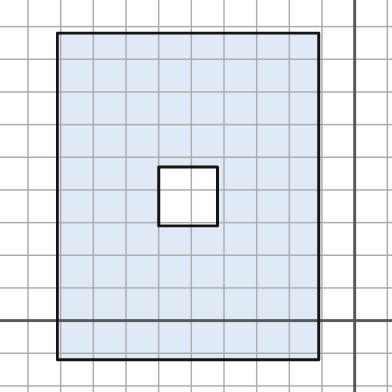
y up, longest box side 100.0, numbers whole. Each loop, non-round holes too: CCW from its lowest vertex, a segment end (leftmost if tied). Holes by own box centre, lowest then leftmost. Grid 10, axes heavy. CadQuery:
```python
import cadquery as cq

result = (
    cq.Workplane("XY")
    .moveTo(-91.0, -12.0)
    .lineTo(-11.0, -12.0)
    .lineTo(-11.0, 88.0)
    .lineTo(-91.0, 88.0)
    .close()
    .moveTo(-60.0, 29.0)
    .lineTo(-42.0, 29.0)
    .lineTo(-42.0, 47.0)
    .lineTo(-60.0, 47.0)
    .close()
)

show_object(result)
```